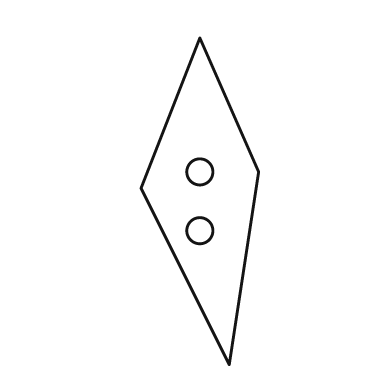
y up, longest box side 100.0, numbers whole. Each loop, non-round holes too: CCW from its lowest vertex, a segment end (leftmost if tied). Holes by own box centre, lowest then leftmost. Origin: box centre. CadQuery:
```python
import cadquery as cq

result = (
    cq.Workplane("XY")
    .moveTo(9.0, -50.0)
    .lineTo(18.0, 9.0)
    .lineTo(0.0, 50.0)
    .lineTo(-18.0, 4.0)
    .close()
    .moveTo(0.0, -9.0)
    .circle(4.0)
    .moveTo(0.0, 9.0)
    .circle(4.0)
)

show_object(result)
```